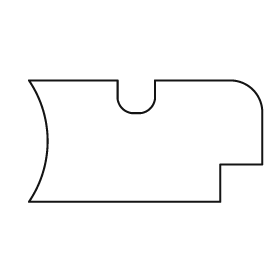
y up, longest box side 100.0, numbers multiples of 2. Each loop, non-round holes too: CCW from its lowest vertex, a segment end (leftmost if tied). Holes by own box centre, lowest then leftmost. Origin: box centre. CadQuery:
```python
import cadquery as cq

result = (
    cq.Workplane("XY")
    .moveTo(-50.0, -26.0)
    .lineTo(32.0, -26.0)
    .lineTo(32.0, -10.0)
    .lineTo(50.0, -10.0)
    .lineTo(50.0, 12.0)
    .threePointArc((46.0, 22.0), (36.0, 26.0))
    .lineTo(4.0, 26.0)
    .lineTo(4.0, 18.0)
    .threePointArc((2.0, 14.0), (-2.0, 12.0))
    .lineTo(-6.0, 12.0)
    .threePointArc((-10.0, 14.0), (-12.0, 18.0))
    .lineTo(-12.0, 26.0)
    .lineTo(-50.0, 26.0)
    .threePointArc((-42.0, 0.0), (-50.0, -26.0))
    .close()
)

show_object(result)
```